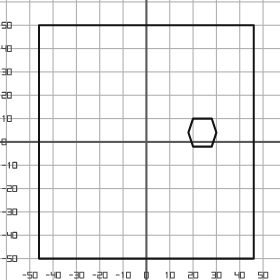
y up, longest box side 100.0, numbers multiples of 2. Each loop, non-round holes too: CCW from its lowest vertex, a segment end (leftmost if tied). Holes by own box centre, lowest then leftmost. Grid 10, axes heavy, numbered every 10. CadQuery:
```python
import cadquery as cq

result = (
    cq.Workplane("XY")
    .moveTo(-46.0, -50.0)
    .lineTo(46.0, -50.0)
    .lineTo(46.0, 50.0)
    .lineTo(-46.0, 50.0)
    .close()
    .moveTo(20.0, -2.0)
    .lineTo(28.0, -2.0)
    .lineTo(30.0, 4.0)
    .lineTo(28.0, 10.0)
    .lineTo(20.0, 10.0)
    .lineTo(18.0, 4.0)
    .close()
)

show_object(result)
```